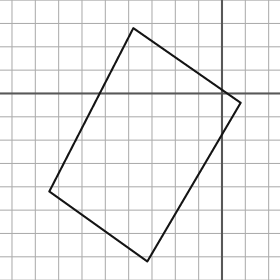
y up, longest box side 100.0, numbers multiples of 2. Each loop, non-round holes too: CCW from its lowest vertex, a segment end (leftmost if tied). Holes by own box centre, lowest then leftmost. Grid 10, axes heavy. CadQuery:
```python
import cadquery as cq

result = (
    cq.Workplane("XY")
    .moveTo(-32.0, -72.0)
    .lineTo(8.0, -4.0)
    .lineTo(-38.0, 28.0)
    .lineTo(-74.0, -42.0)
    .close()
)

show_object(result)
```